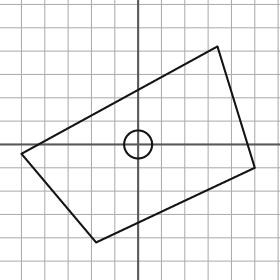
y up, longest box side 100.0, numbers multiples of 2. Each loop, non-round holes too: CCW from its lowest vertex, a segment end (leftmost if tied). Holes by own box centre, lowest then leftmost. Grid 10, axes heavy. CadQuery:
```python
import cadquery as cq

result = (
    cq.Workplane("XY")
    .moveTo(-18.0, -42.0)
    .lineTo(50.0, -10.0)
    .lineTo(34.0, 42.0)
    .lineTo(-50.0, -4.0)
    .close()
    .moveTo(0.0, 0.0)
    .circle(6.0)
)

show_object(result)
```